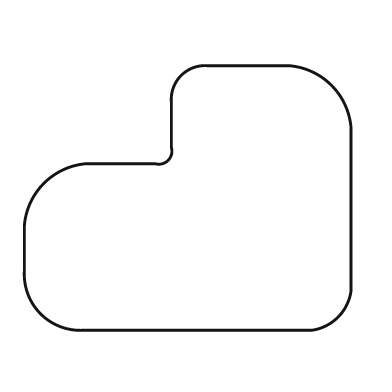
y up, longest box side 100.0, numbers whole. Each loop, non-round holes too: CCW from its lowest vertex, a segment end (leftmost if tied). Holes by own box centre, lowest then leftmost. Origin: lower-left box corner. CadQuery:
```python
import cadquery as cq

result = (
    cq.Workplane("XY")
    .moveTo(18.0, 0.0)
    .lineTo(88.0, 0.0)
    .threePointArc((96.0, 4.0), (100.0, 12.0))
    .lineTo(100.0, 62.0)
    .threePointArc((94.0, 75.0), (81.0, 81.0))
    .lineTo(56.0, 81.0)
    .threePointArc((48.0, 78.0), (45.0, 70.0))
    .lineTo(45.0, 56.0)
    .threePointArc((44.0, 52.0), (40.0, 51.0))
    .lineTo(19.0, 51.0)
    .threePointArc((6.0, 45.0), (0.0, 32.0))
    .lineTo(0.0, 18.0)
    .threePointArc((5.0, 5.0), (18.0, 0.0))
    .close()
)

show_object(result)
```